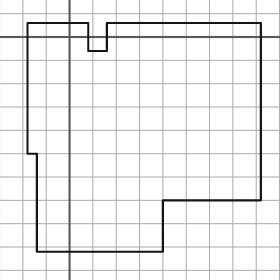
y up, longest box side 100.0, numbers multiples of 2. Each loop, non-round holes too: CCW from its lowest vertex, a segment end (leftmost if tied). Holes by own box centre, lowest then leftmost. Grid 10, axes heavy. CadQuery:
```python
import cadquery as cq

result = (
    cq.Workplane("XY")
    .moveTo(-14.0, -92.0)
    .lineTo(40.0, -92.0)
    .lineTo(40.0, -70.0)
    .lineTo(82.0, -70.0)
    .lineTo(82.0, 6.0)
    .lineTo(16.0, 6.0)
    .lineTo(16.0, -6.0)
    .lineTo(8.0, -6.0)
    .lineTo(8.0, 6.0)
    .lineTo(-18.0, 6.0)
    .lineTo(-18.0, -50.0)
    .lineTo(-14.0, -50.0)
    .close()
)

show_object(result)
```